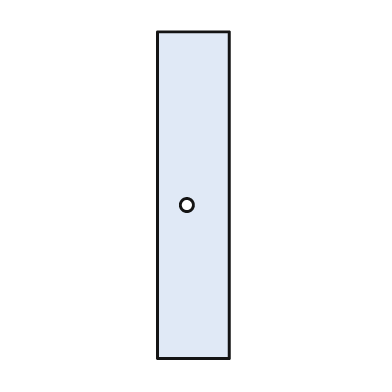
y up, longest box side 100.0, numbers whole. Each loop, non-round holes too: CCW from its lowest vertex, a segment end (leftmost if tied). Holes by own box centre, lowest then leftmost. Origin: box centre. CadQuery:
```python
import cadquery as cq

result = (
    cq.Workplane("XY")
    .moveTo(-11.0, -50.0)
    .lineTo(11.0, -50.0)
    .lineTo(11.0, 50.0)
    .lineTo(-11.0, 50.0)
    .close()
    .moveTo(-2.0, -3.0)
    .circle(2.0)
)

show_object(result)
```